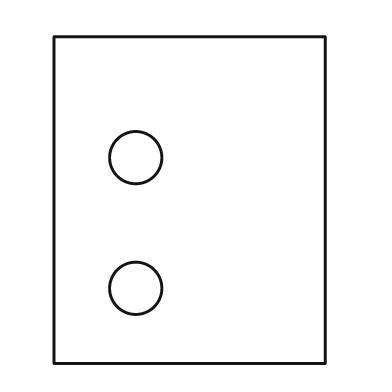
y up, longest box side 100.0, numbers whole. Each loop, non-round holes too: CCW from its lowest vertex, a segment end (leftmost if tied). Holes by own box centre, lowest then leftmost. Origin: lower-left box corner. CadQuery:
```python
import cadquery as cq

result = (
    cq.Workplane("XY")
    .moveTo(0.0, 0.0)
    .lineTo(83.0, 0.0)
    .lineTo(83.0, 100.0)
    .lineTo(0.0, 100.0)
    .close()
    .moveTo(25.0, 23.0)
    .circle(8.0)
    .moveTo(25.0, 63.0)
    .circle(8.0)
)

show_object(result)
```